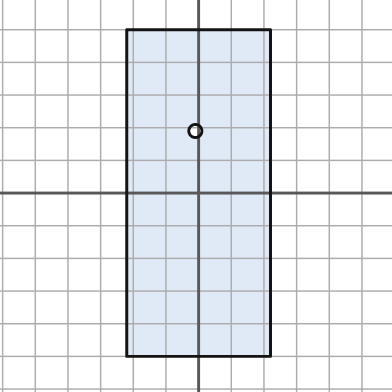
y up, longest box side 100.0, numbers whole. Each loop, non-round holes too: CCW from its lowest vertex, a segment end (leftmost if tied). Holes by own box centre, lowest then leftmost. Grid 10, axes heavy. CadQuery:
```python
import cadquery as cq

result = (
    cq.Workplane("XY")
    .moveTo(-22.0, -50.0)
    .lineTo(22.0, -50.0)
    .lineTo(22.0, 50.0)
    .lineTo(-22.0, 50.0)
    .close()
    .moveTo(-1.0, 19.0)
    .circle(2.0)
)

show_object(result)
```